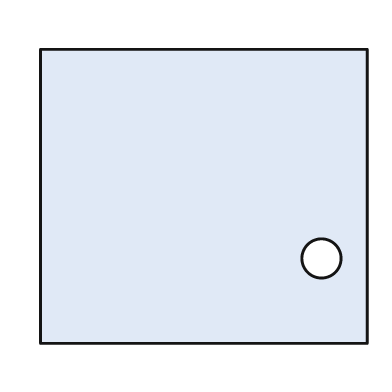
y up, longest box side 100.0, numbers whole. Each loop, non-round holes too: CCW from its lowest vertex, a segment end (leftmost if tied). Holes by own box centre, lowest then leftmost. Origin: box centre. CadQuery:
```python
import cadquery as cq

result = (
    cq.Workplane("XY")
    .moveTo(-50.0, -45.0)
    .lineTo(50.0, -45.0)
    .lineTo(50.0, 45.0)
    .lineTo(-50.0, 45.0)
    .close()
    .moveTo(36.0, -19.0)
    .circle(6.0)
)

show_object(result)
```